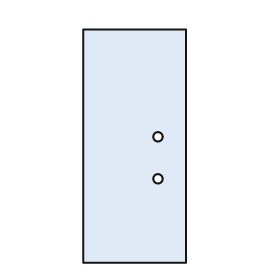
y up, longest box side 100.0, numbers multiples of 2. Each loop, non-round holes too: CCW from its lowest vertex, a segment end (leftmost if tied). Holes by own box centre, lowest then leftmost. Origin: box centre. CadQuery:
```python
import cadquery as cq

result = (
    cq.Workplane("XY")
    .moveTo(-22.0, -50.0)
    .lineTo(22.0, -50.0)
    .lineTo(22.0, 50.0)
    .lineTo(-22.0, 50.0)
    .close()
    .moveTo(10.0, -14.0)
    .circle(2.0)
    .moveTo(10.0, 4.0)
    .circle(2.0)
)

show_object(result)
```